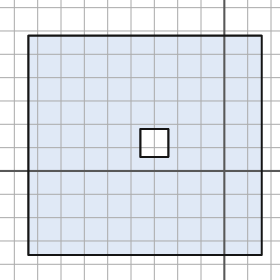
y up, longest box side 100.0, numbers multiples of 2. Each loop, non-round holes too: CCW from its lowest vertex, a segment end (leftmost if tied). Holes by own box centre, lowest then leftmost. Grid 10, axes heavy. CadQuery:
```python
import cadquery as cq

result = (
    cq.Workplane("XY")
    .moveTo(-84.0, -36.0)
    .lineTo(16.0, -36.0)
    .lineTo(16.0, 58.0)
    .lineTo(-84.0, 58.0)
    .close()
    .moveTo(-36.0, 6.0)
    .lineTo(-24.0, 6.0)
    .lineTo(-24.0, 18.0)
    .lineTo(-36.0, 18.0)
    .close()
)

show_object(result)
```